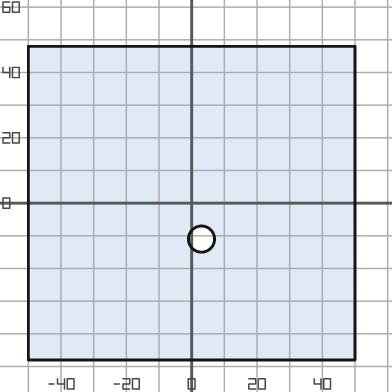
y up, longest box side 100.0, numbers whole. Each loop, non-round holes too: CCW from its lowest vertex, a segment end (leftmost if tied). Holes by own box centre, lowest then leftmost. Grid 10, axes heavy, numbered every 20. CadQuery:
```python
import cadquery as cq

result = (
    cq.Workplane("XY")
    .moveTo(-50.0, -48.0)
    .lineTo(50.0, -48.0)
    .lineTo(50.0, 48.0)
    .lineTo(-50.0, 48.0)
    .close()
    .moveTo(3.0, -11.0)
    .circle(4.0)
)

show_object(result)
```